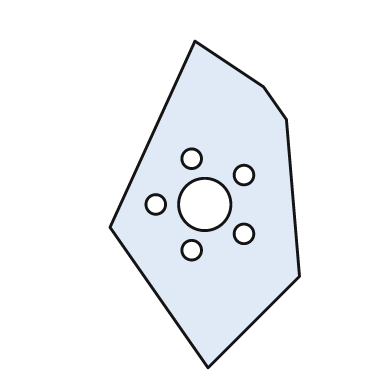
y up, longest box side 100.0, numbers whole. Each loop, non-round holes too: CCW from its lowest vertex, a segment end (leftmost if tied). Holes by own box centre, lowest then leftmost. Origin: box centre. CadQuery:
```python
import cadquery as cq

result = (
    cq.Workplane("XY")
    .moveTo(1.0, -50.0)
    .lineTo(29.0, -22.0)
    .lineTo(25.0, 26.0)
    .lineTo(18.0, 36.0)
    .lineTo(-3.0, 50.0)
    .lineTo(-29.0, -7.0)
    .close()
    .moveTo(-4.0, -14.0)
    .circle(3.0)
    .moveTo(12.0, -9.0)
    .circle(3.0)
    .moveTo(-15.0, 0.0)
    .circle(3.0)
    .moveTo(0.0, 0.0)
    .circle(8.0)
    .moveTo(12.0, 9.0)
    .circle(3.0)
    .moveTo(-4.0, 14.0)
    .circle(3.0)
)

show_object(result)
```